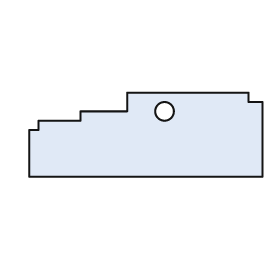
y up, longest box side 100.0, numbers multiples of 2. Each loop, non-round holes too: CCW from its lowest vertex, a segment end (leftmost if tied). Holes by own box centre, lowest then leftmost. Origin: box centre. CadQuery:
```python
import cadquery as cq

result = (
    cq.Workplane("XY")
    .moveTo(-50.0, -18.0)
    .lineTo(50.0, -18.0)
    .lineTo(50.0, 14.0)
    .lineTo(44.0, 14.0)
    .lineTo(44.0, 18.0)
    .lineTo(-8.0, 18.0)
    .lineTo(-8.0, 10.0)
    .lineTo(-28.0, 10.0)
    .lineTo(-28.0, 6.0)
    .lineTo(-46.0, 6.0)
    .lineTo(-46.0, 2.0)
    .lineTo(-50.0, 2.0)
    .close()
    .moveTo(8.0, 10.0)
    .circle(4.0)
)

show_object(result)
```